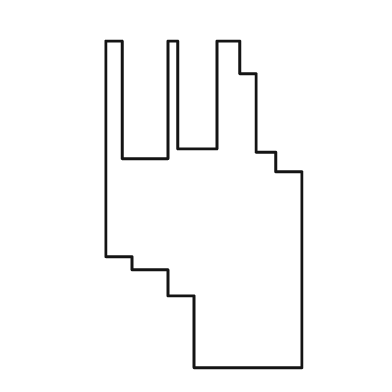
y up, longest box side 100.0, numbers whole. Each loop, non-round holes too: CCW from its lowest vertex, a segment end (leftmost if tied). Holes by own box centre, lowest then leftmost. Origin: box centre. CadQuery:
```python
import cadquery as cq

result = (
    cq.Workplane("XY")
    .moveTo(-3.0, -50.0)
    .lineTo(30.0, -50.0)
    .lineTo(30.0, 10.0)
    .lineTo(22.0, 10.0)
    .lineTo(22.0, 16.0)
    .lineTo(16.0, 16.0)
    .lineTo(16.0, 40.0)
    .lineTo(11.0, 40.0)
    .lineTo(11.0, 50.0)
    .lineTo(4.0, 50.0)
    .lineTo(4.0, 17.0)
    .lineTo(-8.0, 17.0)
    .lineTo(-8.0, 50.0)
    .lineTo(-11.0, 50.0)
    .lineTo(-11.0, 14.0)
    .lineTo(-25.0, 14.0)
    .lineTo(-25.0, 50.0)
    .lineTo(-30.0, 50.0)
    .lineTo(-30.0, -16.0)
    .lineTo(-22.0, -16.0)
    .lineTo(-22.0, -20.0)
    .lineTo(-11.0, -20.0)
    .lineTo(-11.0, -28.0)
    .lineTo(-3.0, -28.0)
    .close()
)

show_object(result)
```